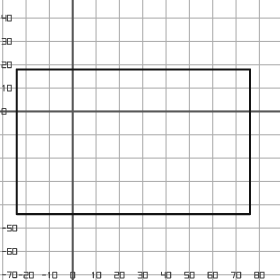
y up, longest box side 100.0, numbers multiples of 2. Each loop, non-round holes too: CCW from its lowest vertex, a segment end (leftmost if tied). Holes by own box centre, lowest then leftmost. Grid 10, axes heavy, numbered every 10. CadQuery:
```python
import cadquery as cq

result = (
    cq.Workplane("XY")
    .moveTo(-24.0, -44.0)
    .lineTo(76.0, -44.0)
    .lineTo(76.0, 18.0)
    .lineTo(-24.0, 18.0)
    .close()
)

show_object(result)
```